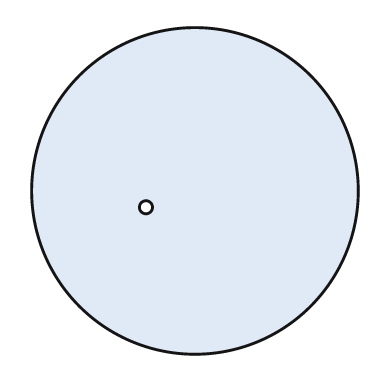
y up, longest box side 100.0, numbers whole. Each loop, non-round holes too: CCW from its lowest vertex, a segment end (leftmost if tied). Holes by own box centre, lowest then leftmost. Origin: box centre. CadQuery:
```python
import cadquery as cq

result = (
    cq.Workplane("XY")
    .moveTo(0.0, 0.0)
    .circle(50.0)
    .moveTo(-15.0, -5.0)
    .circle(2.0)
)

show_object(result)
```